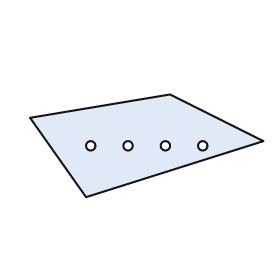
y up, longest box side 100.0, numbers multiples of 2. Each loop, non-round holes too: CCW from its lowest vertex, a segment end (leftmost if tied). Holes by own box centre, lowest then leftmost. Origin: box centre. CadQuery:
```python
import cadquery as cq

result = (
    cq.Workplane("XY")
    .moveTo(-26.0, -22.0)
    .lineTo(50.0, 2.0)
    .lineTo(10.0, 22.0)
    .lineTo(-50.0, 12.0)
    .close()
    .moveTo(-24.0, 0.0)
    .circle(2.0)
    .moveTo(-8.0, 0.0)
    .circle(2.0)
    .moveTo(8.0, 0.0)
    .circle(2.0)
    .moveTo(24.0, 0.0)
    .circle(2.0)
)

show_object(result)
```